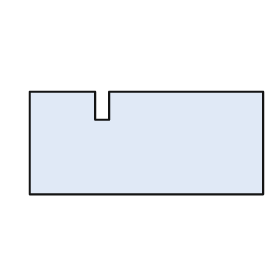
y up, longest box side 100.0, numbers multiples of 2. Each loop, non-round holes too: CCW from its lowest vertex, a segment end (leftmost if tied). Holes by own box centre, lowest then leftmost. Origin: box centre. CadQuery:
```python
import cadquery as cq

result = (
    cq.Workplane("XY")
    .moveTo(-50.0, -22.0)
    .lineTo(50.0, -22.0)
    .lineTo(50.0, 22.0)
    .lineTo(-16.0, 22.0)
    .lineTo(-16.0, 10.0)
    .lineTo(-22.0, 10.0)
    .lineTo(-22.0, 22.0)
    .lineTo(-50.0, 22.0)
    .close()
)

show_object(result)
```